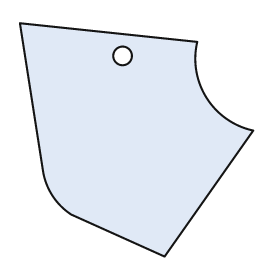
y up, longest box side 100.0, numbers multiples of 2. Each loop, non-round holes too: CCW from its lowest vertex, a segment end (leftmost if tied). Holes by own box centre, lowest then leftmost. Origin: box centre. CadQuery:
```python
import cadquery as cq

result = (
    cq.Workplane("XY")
    .moveTo(12.0, -50.0)
    .lineTo(50.0, 4.0)
    .threePointArc((30.0, 18.0), (26.0, 42.0))
    .lineTo(-50.0, 50.0)
    .lineTo(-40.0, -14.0)
    .threePointArc((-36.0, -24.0), (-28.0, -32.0))
    .close()
    .moveTo(-6.0, 36.0)
    .circle(4.0)
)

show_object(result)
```